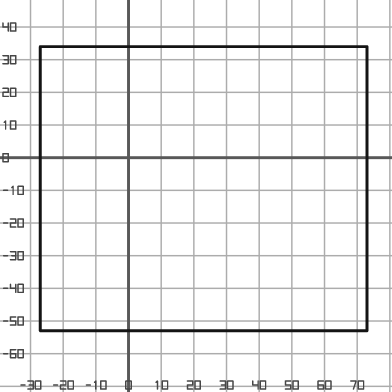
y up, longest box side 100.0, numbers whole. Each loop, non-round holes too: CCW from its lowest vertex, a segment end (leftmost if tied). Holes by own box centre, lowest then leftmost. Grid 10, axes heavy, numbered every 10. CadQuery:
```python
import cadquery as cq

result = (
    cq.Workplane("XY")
    .moveTo(-27.0, -53.0)
    .lineTo(73.0, -53.0)
    .lineTo(73.0, 34.0)
    .lineTo(-27.0, 34.0)
    .close()
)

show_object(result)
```